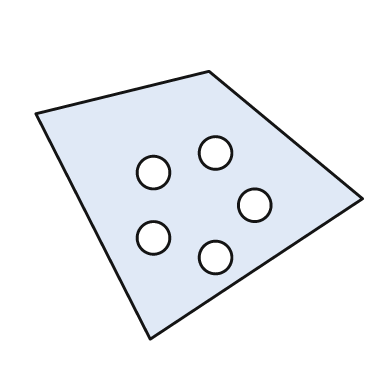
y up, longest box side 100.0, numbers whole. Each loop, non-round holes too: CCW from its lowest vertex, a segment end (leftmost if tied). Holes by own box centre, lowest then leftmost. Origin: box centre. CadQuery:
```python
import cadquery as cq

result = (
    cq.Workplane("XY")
    .moveTo(-15.0, -41.0)
    .lineTo(50.0, 2.0)
    .lineTo(3.0, 41.0)
    .lineTo(-50.0, 28.0)
    .close()
    .moveTo(5.0, -16.0)
    .circle(5.0)
    .moveTo(-14.0, -10.0)
    .circle(5.0)
    .moveTo(17.0, 0.0)
    .circle(5.0)
    .moveTo(-14.0, 10.0)
    .circle(5.0)
    .moveTo(5.0, 16.0)
    .circle(5.0)
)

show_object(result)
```